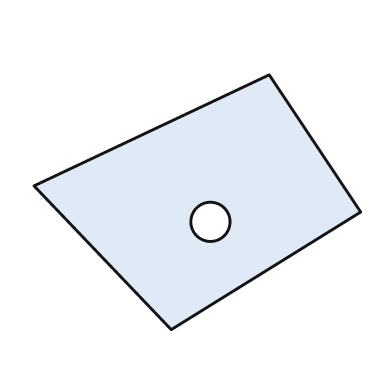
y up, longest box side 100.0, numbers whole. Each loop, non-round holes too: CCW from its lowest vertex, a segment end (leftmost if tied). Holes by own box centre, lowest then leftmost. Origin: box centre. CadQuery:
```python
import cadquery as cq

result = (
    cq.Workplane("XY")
    .moveTo(-8.0, -39.0)
    .lineTo(50.0, -3.0)
    .lineTo(22.0, 39.0)
    .lineTo(-50.0, 5.0)
    .close()
    .moveTo(4.0, -6.0)
    .circle(6.0)
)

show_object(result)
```